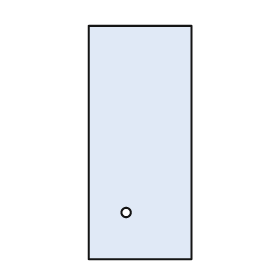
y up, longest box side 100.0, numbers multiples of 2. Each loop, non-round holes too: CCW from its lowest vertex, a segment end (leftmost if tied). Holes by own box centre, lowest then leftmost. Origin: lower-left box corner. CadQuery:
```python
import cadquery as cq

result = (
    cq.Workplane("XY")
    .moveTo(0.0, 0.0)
    .lineTo(44.0, 0.0)
    .lineTo(44.0, 100.0)
    .lineTo(0.0, 100.0)
    .close()
    .moveTo(16.0, 20.0)
    .circle(2.0)
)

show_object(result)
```